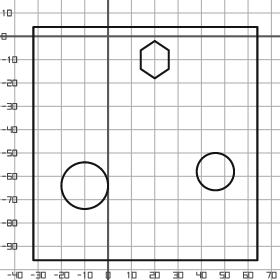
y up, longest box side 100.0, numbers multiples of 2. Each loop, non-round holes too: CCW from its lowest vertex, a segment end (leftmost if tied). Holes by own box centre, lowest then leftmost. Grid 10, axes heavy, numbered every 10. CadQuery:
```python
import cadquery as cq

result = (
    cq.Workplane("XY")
    .moveTo(-32.0, -96.0)
    .lineTo(64.0, -96.0)
    .lineTo(64.0, 4.0)
    .lineTo(-32.0, 4.0)
    .close()
    .moveTo(-10.0, -64.0)
    .circle(10.0)
    .moveTo(46.0, -58.0)
    .circle(8.0)
    .moveTo(20.0, -18.0)
    .lineTo(26.0, -14.0)
    .lineTo(26.0, -6.0)
    .lineTo(20.0, -2.0)
    .lineTo(14.0, -6.0)
    .lineTo(14.0, -14.0)
    .close()
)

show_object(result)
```